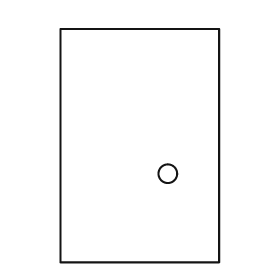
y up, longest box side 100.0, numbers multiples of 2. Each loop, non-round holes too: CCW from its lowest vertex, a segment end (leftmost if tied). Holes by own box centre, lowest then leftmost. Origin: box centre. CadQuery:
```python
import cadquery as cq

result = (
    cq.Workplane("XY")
    .moveTo(-34.0, -50.0)
    .lineTo(34.0, -50.0)
    .lineTo(34.0, 50.0)
    .lineTo(-34.0, 50.0)
    .close()
    .moveTo(12.0, -12.0)
    .circle(4.0)
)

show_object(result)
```